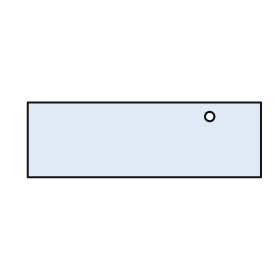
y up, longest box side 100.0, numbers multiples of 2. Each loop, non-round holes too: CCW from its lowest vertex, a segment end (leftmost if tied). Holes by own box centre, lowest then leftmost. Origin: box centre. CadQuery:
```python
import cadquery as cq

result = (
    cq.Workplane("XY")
    .moveTo(-50.0, -16.0)
    .lineTo(50.0, -16.0)
    .lineTo(50.0, 16.0)
    .lineTo(-50.0, 16.0)
    .close()
    .moveTo(28.0, 10.0)
    .circle(2.0)
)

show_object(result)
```